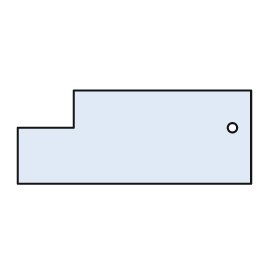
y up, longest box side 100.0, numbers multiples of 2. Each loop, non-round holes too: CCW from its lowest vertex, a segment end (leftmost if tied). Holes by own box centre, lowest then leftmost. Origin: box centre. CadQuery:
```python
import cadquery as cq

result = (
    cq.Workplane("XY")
    .moveTo(-50.0, -20.0)
    .lineTo(50.0, -20.0)
    .lineTo(50.0, 20.0)
    .lineTo(-26.0, 20.0)
    .lineTo(-26.0, 4.0)
    .lineTo(-50.0, 4.0)
    .close()
    .moveTo(42.0, 4.0)
    .circle(2.0)
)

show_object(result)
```